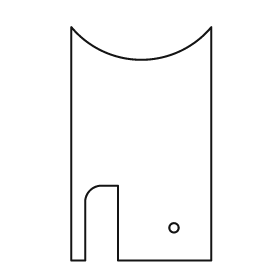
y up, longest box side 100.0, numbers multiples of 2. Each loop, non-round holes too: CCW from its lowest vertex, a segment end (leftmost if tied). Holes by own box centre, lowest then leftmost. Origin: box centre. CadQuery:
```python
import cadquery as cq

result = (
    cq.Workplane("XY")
    .moveTo(-30.0, -50.0)
    .lineTo(-24.0, -50.0)
    .lineTo(-24.0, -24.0)
    .threePointArc((-22.0, -20.0), (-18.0, -18.0))
    .lineTo(-10.0, -18.0)
    .lineTo(-10.0, -50.0)
    .lineTo(30.0, -50.0)
    .lineTo(30.0, 50.0)
    .threePointArc((0.0, 36.0), (-30.0, 50.0))
    .close()
    .moveTo(14.0, -36.0)
    .circle(2.0)
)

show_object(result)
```